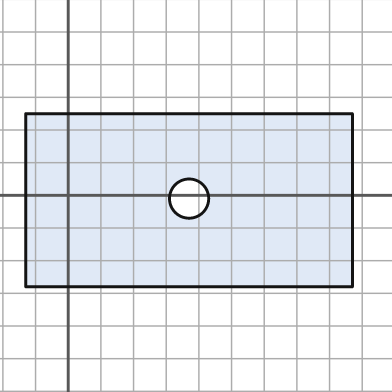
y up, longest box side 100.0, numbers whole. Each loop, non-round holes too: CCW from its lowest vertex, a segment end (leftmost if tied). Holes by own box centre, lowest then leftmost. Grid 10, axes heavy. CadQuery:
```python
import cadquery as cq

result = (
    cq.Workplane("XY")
    .moveTo(-13.0, -28.0)
    .lineTo(87.0, -28.0)
    .lineTo(87.0, 25.0)
    .lineTo(-13.0, 25.0)
    .close()
    .moveTo(37.0, -1.0)
    .circle(6.0)
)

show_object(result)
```